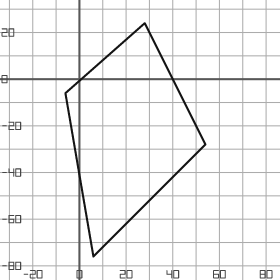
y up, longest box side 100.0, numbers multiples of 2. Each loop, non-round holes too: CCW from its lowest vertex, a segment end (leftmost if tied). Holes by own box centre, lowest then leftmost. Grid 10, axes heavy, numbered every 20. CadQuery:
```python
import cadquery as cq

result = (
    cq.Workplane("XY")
    .moveTo(6.0, -76.0)
    .lineTo(54.0, -28.0)
    .lineTo(28.0, 24.0)
    .lineTo(-6.0, -6.0)
    .close()
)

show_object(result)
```